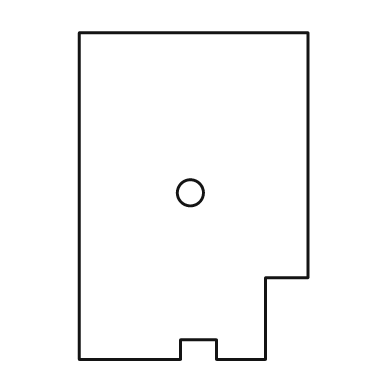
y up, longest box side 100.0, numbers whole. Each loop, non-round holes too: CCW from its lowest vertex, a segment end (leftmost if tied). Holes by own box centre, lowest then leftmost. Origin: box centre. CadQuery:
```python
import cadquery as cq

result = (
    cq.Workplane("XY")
    .moveTo(-35.0, -50.0)
    .lineTo(-4.0, -50.0)
    .lineTo(-4.0, -44.0)
    .lineTo(7.0, -44.0)
    .lineTo(7.0, -50.0)
    .lineTo(22.0, -50.0)
    .lineTo(22.0, -25.0)
    .lineTo(35.0, -25.0)
    .lineTo(35.0, 50.0)
    .lineTo(-35.0, 50.0)
    .close()
    .moveTo(-1.0, 1.0)
    .circle(4.0)
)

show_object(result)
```